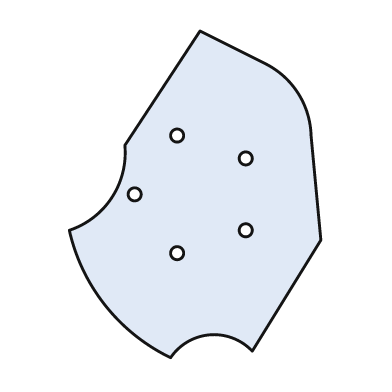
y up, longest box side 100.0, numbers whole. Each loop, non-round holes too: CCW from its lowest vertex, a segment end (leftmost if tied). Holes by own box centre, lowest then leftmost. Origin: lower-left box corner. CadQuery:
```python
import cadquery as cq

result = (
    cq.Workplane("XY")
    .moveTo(31.0, 0.0)
    .threePointArc((43.0, 7.0), (56.0, 2.0))
    .lineTo(77.0, 36.0)
    .lineTo(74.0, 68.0)
    .threePointArc((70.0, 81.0), (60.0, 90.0))
    .lineTo(40.0, 100.0)
    .lineTo(17.0, 65.0)
    .threePointArc((13.0, 49.0), (0.0, 39.0))
    .threePointArc((11.0, 16.0), (31.0, 0.0))
    .close()
    .moveTo(33.0, 32.0)
    .circle(2.0)
    .moveTo(54.0, 39.0)
    .circle(2.0)
    .moveTo(20.0, 50.0)
    .circle(2.0)
    .moveTo(54.0, 61.0)
    .circle(2.0)
    .moveTo(33.0, 68.0)
    .circle(2.0)
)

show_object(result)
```